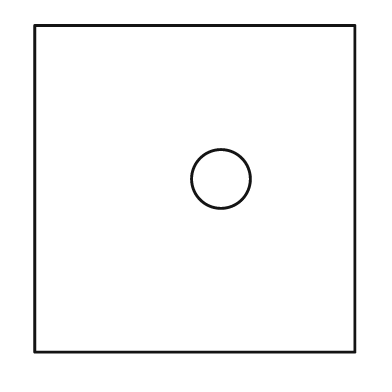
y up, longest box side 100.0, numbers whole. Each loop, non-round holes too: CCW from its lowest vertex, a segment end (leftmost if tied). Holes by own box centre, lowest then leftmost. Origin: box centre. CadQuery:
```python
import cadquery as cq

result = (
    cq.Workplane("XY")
    .moveTo(-49.0, -50.0)
    .lineTo(49.0, -50.0)
    .lineTo(49.0, 50.0)
    .lineTo(-49.0, 50.0)
    .close()
    .moveTo(8.0, 3.0)
    .circle(9.0)
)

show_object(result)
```